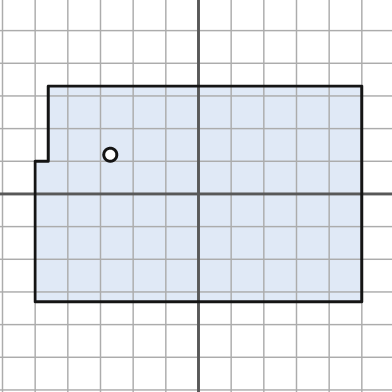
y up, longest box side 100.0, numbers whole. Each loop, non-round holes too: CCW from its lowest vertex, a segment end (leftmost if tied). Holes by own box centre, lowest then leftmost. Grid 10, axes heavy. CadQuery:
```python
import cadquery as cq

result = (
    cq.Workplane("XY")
    .moveTo(-50.0, -33.0)
    .lineTo(50.0, -33.0)
    .lineTo(50.0, 33.0)
    .lineTo(-46.0, 33.0)
    .lineTo(-46.0, 10.0)
    .lineTo(-50.0, 10.0)
    .close()
    .moveTo(-27.0, 12.0)
    .circle(2.0)
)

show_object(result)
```